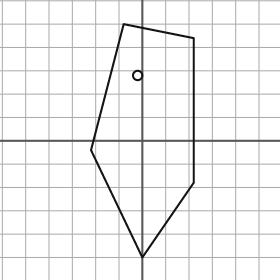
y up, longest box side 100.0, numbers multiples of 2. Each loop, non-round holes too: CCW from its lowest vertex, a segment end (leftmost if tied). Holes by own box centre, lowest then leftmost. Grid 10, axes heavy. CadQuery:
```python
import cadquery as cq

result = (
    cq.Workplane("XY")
    .moveTo(0.0, -50.0)
    .lineTo(22.0, -18.0)
    .lineTo(22.0, 44.0)
    .lineTo(-8.0, 50.0)
    .lineTo(-22.0, -4.0)
    .close()
    .moveTo(-2.0, 28.0)
    .circle(2.0)
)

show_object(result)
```